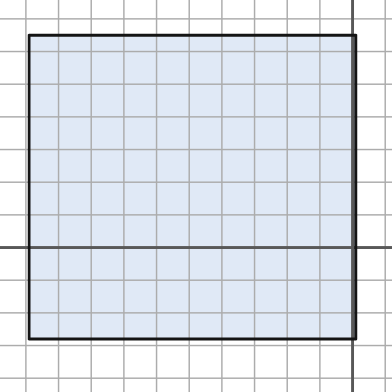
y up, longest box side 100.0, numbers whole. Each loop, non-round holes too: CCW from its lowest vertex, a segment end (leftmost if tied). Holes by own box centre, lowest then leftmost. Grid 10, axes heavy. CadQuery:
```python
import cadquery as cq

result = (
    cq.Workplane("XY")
    .moveTo(-99.0, -28.0)
    .lineTo(1.0, -28.0)
    .lineTo(1.0, 65.0)
    .lineTo(-99.0, 65.0)
    .close()
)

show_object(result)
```